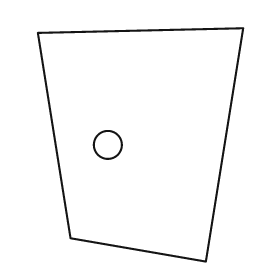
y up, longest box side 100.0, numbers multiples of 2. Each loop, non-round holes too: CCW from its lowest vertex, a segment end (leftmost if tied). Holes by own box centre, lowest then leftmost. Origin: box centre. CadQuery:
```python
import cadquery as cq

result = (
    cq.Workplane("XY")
    .moveTo(28.0, -50.0)
    .lineTo(44.0, 50.0)
    .lineTo(-44.0, 48.0)
    .lineTo(-30.0, -40.0)
    .close()
    .moveTo(-14.0, 0.0)
    .circle(6.0)
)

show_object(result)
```